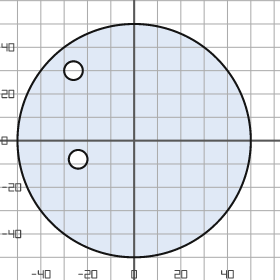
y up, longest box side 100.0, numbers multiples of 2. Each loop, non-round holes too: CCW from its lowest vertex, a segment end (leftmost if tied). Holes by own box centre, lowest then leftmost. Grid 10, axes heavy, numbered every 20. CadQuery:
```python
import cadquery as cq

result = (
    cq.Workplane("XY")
    .moveTo(0.0, 0.0)
    .circle(50.0)
    .moveTo(-24.0, -8.0)
    .circle(4.0)
    .moveTo(-26.0, 30.0)
    .circle(4.0)
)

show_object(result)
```